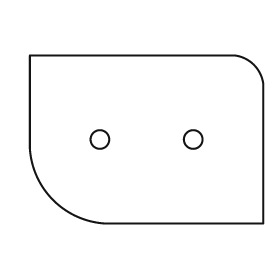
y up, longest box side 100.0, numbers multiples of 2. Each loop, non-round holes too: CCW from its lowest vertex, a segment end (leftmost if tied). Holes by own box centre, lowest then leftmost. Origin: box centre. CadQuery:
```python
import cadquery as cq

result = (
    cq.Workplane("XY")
    .moveTo(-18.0, -36.0)
    .lineTo(50.0, -36.0)
    .lineTo(50.0, 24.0)
    .threePointArc((46.0, 32.0), (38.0, 36.0))
    .lineTo(-50.0, 36.0)
    .lineTo(-50.0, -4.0)
    .threePointArc((-40.0, -26.0), (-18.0, -36.0))
    .close()
    .moveTo(-20.0, 0.0)
    .circle(4.0)
    .moveTo(20.0, 0.0)
    .circle(4.0)
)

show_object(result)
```